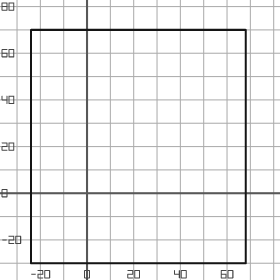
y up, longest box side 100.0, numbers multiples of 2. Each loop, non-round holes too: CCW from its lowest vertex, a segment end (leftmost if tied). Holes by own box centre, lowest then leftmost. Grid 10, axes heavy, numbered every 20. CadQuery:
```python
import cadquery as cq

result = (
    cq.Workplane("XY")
    .moveTo(-24.0, -30.0)
    .lineTo(68.0, -30.0)
    .lineTo(68.0, 70.0)
    .lineTo(-24.0, 70.0)
    .close()
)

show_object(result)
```